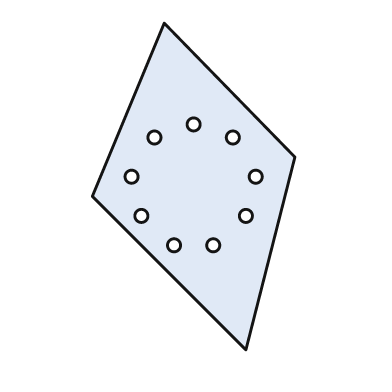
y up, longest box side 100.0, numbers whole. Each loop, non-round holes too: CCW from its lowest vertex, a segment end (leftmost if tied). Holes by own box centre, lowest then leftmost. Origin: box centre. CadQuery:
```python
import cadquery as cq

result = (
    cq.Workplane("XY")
    .moveTo(16.0, -50.0)
    .lineTo(31.0, 9.0)
    .lineTo(-9.0, 50.0)
    .lineTo(-31.0, -3.0)
    .close()
    .moveTo(-6.0, -18.0)
    .circle(2.0)
    .moveTo(6.0, -18.0)
    .circle(2.0)
    .moveTo(-16.0, -9.0)
    .circle(2.0)
    .moveTo(16.0, -9.0)
    .circle(2.0)
    .moveTo(-19.0, 3.0)
    .circle(2.0)
    .moveTo(19.0, 3.0)
    .circle(2.0)
    .moveTo(-12.0, 15.0)
    .circle(2.0)
    .moveTo(12.0, 15.0)
    .circle(2.0)
    .moveTo(0.0, 19.0)
    .circle(2.0)
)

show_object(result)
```